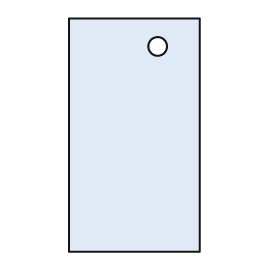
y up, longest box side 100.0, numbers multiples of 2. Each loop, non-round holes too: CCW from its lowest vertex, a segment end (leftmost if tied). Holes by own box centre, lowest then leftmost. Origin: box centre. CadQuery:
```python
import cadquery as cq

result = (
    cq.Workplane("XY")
    .moveTo(-28.0, -50.0)
    .lineTo(28.0, -50.0)
    .lineTo(28.0, 50.0)
    .lineTo(-28.0, 50.0)
    .close()
    .moveTo(10.0, 38.0)
    .circle(4.0)
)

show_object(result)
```